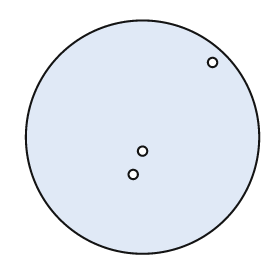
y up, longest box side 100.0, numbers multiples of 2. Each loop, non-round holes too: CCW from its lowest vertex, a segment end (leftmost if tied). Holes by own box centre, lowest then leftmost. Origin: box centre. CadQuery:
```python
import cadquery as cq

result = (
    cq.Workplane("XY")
    .moveTo(0.0, 0.0)
    .circle(50.0)
    .moveTo(-4.0, -16.0)
    .circle(2.0)
    .moveTo(0.0, -6.0)
    .circle(2.0)
    .moveTo(30.0, 32.0)
    .circle(2.0)
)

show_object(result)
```